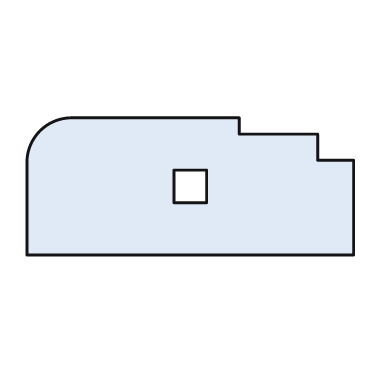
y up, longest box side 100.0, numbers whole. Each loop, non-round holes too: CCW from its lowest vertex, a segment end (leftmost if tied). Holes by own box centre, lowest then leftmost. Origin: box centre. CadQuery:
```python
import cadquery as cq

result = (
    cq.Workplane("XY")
    .moveTo(-50.0, -21.0)
    .lineTo(50.0, -21.0)
    .lineTo(50.0, 8.0)
    .lineTo(39.0, 8.0)
    .lineTo(39.0, 16.0)
    .lineTo(15.0, 16.0)
    .lineTo(15.0, 21.0)
    .lineTo(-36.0, 21.0)
    .threePointArc((-46.0, 17.0), (-50.0, 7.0))
    .close()
    .moveTo(-5.0, -5.0)
    .lineTo(5.0, -5.0)
    .lineTo(5.0, 5.0)
    .lineTo(-5.0, 5.0)
    .close()
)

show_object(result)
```